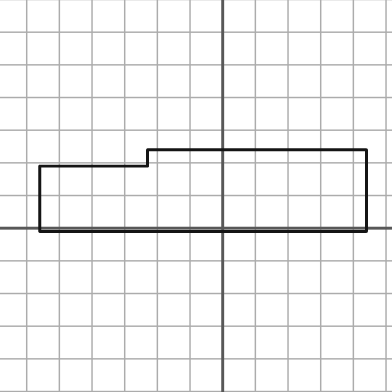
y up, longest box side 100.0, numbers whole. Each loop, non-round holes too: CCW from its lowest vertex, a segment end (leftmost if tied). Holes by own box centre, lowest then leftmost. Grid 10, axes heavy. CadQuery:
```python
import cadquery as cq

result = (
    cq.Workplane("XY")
    .moveTo(-56.0, -1.0)
    .lineTo(44.0, -1.0)
    .lineTo(44.0, 24.0)
    .lineTo(-23.0, 24.0)
    .lineTo(-23.0, 19.0)
    .lineTo(-56.0, 19.0)
    .close()
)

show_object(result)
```